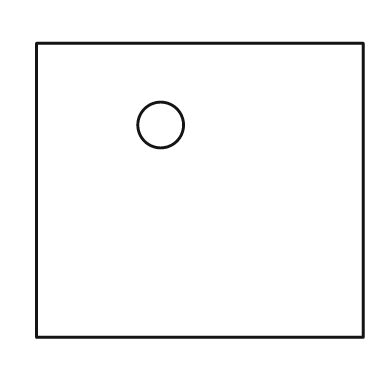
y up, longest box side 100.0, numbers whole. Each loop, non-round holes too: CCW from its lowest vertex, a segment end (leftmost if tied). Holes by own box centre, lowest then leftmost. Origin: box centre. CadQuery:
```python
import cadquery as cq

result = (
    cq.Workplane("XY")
    .moveTo(-50.0, -45.0)
    .lineTo(50.0, -45.0)
    .lineTo(50.0, 45.0)
    .lineTo(-50.0, 45.0)
    .close()
    .moveTo(-12.0, 20.0)
    .circle(7.0)
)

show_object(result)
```